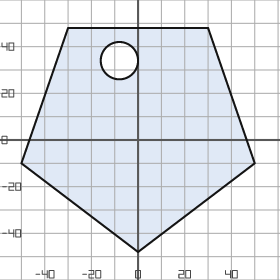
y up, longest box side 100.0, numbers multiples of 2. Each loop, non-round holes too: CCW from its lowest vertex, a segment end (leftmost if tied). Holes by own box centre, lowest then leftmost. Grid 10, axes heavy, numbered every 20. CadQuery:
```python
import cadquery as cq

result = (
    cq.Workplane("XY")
    .moveTo(0.0, -48.0)
    .lineTo(50.0, -10.0)
    .lineTo(30.0, 48.0)
    .lineTo(-30.0, 48.0)
    .lineTo(-50.0, -10.0)
    .close()
    .moveTo(-8.0, 34.0)
    .circle(8.0)
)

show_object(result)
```